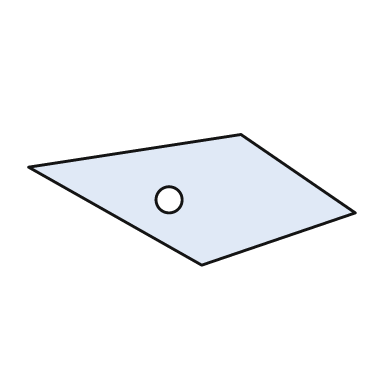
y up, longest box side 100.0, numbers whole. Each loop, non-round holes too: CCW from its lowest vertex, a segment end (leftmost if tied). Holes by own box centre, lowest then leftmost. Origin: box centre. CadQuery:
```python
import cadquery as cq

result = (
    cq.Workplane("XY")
    .moveTo(3.0, -20.0)
    .lineTo(50.0, -4.0)
    .lineTo(15.0, 20.0)
    .lineTo(-50.0, 10.0)
    .close()
    .moveTo(-7.0, 0.0)
    .circle(4.0)
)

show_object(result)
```